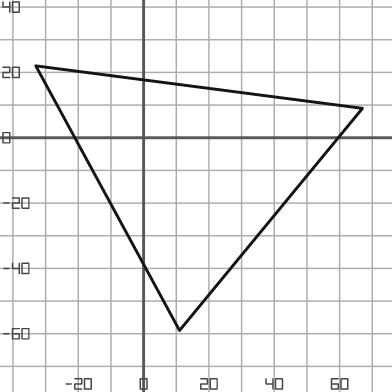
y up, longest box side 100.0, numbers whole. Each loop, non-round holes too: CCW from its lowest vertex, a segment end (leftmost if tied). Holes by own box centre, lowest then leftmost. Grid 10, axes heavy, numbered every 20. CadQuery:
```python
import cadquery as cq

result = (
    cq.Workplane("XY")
    .moveTo(11.0, -59.0)
    .lineTo(67.0, 9.0)
    .lineTo(-33.0, 22.0)
    .close()
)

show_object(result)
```